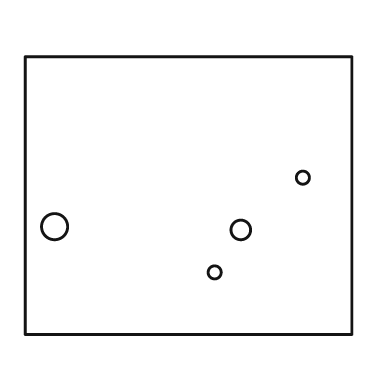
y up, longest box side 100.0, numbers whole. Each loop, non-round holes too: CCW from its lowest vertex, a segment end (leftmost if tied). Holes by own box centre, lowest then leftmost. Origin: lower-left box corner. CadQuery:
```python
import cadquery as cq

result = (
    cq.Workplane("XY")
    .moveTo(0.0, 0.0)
    .lineTo(100.0, 0.0)
    .lineTo(100.0, 85.0)
    .lineTo(0.0, 85.0)
    .close()
    .moveTo(58.0, 19.0)
    .circle(2.0)
    .moveTo(66.0, 32.0)
    .circle(3.0)
    .moveTo(9.0, 33.0)
    .circle(4.0)
    .moveTo(85.0, 48.0)
    .circle(2.0)
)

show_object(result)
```